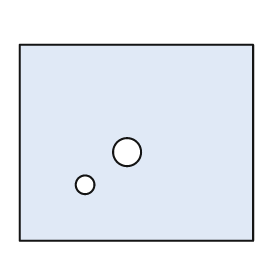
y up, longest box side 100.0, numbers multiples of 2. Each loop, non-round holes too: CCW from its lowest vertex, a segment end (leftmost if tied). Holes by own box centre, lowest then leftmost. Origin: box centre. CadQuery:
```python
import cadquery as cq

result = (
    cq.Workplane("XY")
    .moveTo(-50.0, -42.0)
    .lineTo(50.0, -42.0)
    .lineTo(50.0, 42.0)
    .lineTo(-50.0, 42.0)
    .close()
    .moveTo(-22.0, -18.0)
    .circle(4.0)
    .moveTo(-4.0, -4.0)
    .circle(6.0)
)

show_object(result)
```